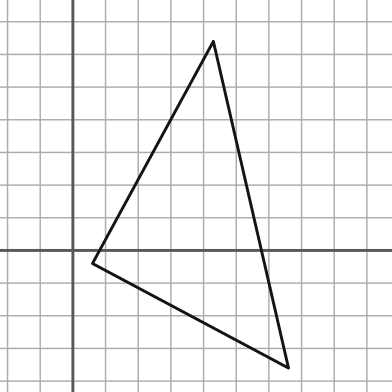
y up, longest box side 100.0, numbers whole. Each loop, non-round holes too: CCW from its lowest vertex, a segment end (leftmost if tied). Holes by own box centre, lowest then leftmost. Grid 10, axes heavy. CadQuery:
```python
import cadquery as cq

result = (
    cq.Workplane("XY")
    .moveTo(66.0, -36.0)
    .lineTo(43.0, 64.0)
    .lineTo(6.0, -4.0)
    .close()
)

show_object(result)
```